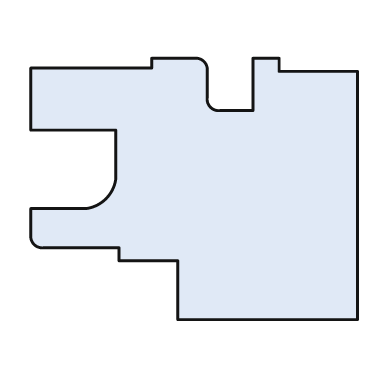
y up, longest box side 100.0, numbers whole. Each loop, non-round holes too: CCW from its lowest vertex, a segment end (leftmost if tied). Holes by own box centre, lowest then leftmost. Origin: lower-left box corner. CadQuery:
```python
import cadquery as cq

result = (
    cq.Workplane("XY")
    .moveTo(45.0, 0.0)
    .lineTo(100.0, 0.0)
    .lineTo(100.0, 76.0)
    .lineTo(76.0, 76.0)
    .lineTo(76.0, 80.0)
    .lineTo(68.0, 80.0)
    .lineTo(68.0, 64.0)
    .lineTo(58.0, 64.0)
    .threePointArc((55.0, 65.0), (54.0, 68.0))
    .lineTo(54.0, 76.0)
    .threePointArc((53.0, 79.0), (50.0, 80.0))
    .lineTo(37.0, 80.0)
    .lineTo(37.0, 77.0)
    .lineTo(0.0, 77.0)
    .lineTo(0.0, 58.0)
    .lineTo(26.0, 58.0)
    .lineTo(26.0, 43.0)
    .threePointArc((23.0, 37.0), (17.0, 34.0))
    .lineTo(0.0, 34.0)
    .lineTo(0.0, 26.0)
    .threePointArc((1.0, 23.0), (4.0, 22.0))
    .lineTo(27.0, 22.0)
    .lineTo(27.0, 18.0)
    .lineTo(45.0, 18.0)
    .close()
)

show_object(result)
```